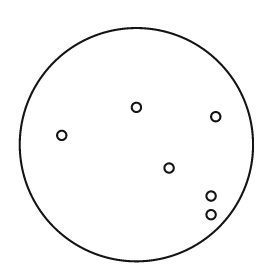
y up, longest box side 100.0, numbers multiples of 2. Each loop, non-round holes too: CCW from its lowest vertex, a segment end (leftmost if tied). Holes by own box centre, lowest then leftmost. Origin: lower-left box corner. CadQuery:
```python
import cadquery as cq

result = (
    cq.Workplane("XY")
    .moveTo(50.0, 50.0)
    .circle(50.0)
    .moveTo(82.0, 20.0)
    .circle(2.0)
    .moveTo(82.0, 28.0)
    .circle(2.0)
    .moveTo(64.0, 40.0)
    .circle(2.0)
    .moveTo(18.0, 54.0)
    .circle(2.0)
    .moveTo(84.0, 62.0)
    .circle(2.0)
    .moveTo(50.0, 66.0)
    .circle(2.0)
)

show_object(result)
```